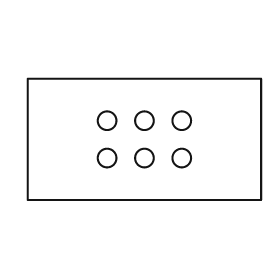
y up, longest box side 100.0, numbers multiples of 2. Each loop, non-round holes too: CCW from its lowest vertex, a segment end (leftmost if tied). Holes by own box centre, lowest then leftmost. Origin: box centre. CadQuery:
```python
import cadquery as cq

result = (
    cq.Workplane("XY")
    .moveTo(-50.0, -26.0)
    .lineTo(50.0, -26.0)
    .lineTo(50.0, 26.0)
    .lineTo(-50.0, 26.0)
    .close()
    .moveTo(-16.0, -8.0)
    .circle(4.0)
    .moveTo(0.0, -8.0)
    .circle(4.0)
    .moveTo(16.0, -8.0)
    .circle(4.0)
    .moveTo(-16.0, 8.0)
    .circle(4.0)
    .moveTo(0.0, 8.0)
    .circle(4.0)
    .moveTo(16.0, 8.0)
    .circle(4.0)
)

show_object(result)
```